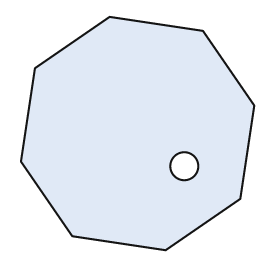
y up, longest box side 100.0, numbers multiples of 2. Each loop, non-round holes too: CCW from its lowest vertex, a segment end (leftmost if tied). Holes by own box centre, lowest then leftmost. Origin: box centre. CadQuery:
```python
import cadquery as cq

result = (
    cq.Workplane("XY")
    .moveTo(12.0, -50.0)
    .lineTo(44.0, -28.0)
    .lineTo(50.0, 12.0)
    .lineTo(28.0, 44.0)
    .lineTo(-12.0, 50.0)
    .lineTo(-44.0, 28.0)
    .lineTo(-50.0, -12.0)
    .lineTo(-28.0, -44.0)
    .close()
    .moveTo(20.0, -14.0)
    .circle(6.0)
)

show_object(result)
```